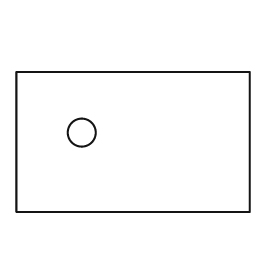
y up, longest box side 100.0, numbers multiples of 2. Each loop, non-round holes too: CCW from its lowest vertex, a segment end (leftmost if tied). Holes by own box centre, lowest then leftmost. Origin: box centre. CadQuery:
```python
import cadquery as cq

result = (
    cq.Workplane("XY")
    .moveTo(-50.0, -30.0)
    .lineTo(50.0, -30.0)
    .lineTo(50.0, 30.0)
    .lineTo(-50.0, 30.0)
    .close()
    .moveTo(-22.0, 4.0)
    .circle(6.0)
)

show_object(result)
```